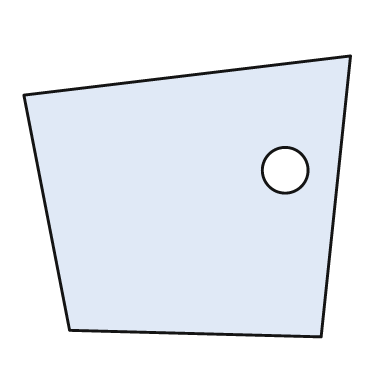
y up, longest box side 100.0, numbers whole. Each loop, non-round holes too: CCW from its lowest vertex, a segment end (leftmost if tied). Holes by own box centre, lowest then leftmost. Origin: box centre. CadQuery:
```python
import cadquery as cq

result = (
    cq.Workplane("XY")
    .moveTo(41.0, -43.0)
    .lineTo(50.0, 43.0)
    .lineTo(-50.0, 31.0)
    .lineTo(-36.0, -41.0)
    .close()
    .moveTo(30.0, 8.0)
    .circle(7.0)
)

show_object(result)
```